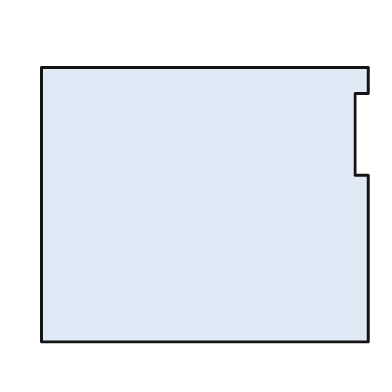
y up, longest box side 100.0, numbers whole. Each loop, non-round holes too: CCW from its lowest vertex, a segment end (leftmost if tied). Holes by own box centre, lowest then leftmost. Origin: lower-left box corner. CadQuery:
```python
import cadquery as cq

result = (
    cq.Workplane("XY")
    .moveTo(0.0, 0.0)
    .lineTo(100.0, 0.0)
    .lineTo(100.0, 51.0)
    .lineTo(96.0, 51.0)
    .lineTo(96.0, 76.0)
    .lineTo(100.0, 76.0)
    .lineTo(100.0, 84.0)
    .lineTo(0.0, 84.0)
    .close()
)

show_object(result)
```